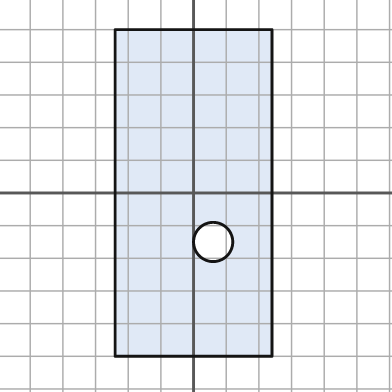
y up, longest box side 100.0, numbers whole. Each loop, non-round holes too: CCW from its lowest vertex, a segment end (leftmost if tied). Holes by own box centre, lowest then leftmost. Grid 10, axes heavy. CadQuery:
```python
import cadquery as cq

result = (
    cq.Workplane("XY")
    .moveTo(-24.0, -50.0)
    .lineTo(24.0, -50.0)
    .lineTo(24.0, 50.0)
    .lineTo(-24.0, 50.0)
    .close()
    .moveTo(6.0, -15.0)
    .circle(6.0)
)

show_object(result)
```